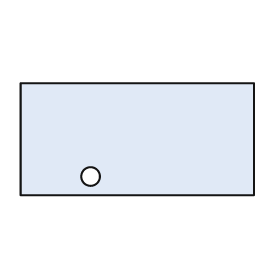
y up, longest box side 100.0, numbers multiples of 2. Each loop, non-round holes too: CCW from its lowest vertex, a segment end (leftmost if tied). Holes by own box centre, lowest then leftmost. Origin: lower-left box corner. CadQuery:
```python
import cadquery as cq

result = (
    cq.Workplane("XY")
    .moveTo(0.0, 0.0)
    .lineTo(100.0, 0.0)
    .lineTo(100.0, 48.0)
    .lineTo(0.0, 48.0)
    .close()
    .moveTo(30.0, 8.0)
    .circle(4.0)
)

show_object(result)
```